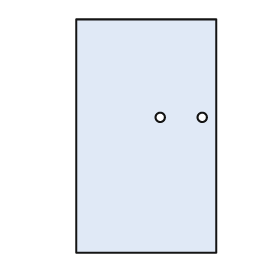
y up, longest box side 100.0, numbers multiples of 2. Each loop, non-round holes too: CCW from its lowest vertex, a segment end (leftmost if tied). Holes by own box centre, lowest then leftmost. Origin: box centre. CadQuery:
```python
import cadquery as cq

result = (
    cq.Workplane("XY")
    .moveTo(-30.0, -50.0)
    .lineTo(30.0, -50.0)
    .lineTo(30.0, 50.0)
    .lineTo(-30.0, 50.0)
    .close()
    .moveTo(6.0, 8.0)
    .circle(2.0)
    .moveTo(24.0, 8.0)
    .circle(2.0)
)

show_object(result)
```